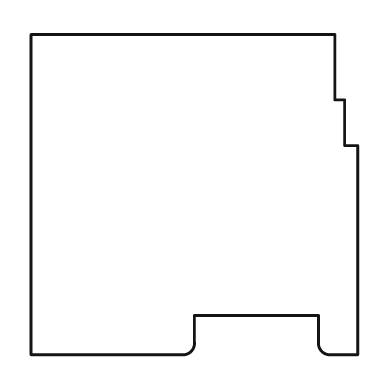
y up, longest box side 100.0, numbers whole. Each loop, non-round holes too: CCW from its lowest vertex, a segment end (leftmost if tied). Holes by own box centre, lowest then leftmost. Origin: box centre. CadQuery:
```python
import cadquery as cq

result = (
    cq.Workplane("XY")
    .moveTo(-50.0, -49.0)
    .lineTo(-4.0, -49.0)
    .threePointArc((-1.0, -48.0), (0.0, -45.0))
    .lineTo(0.0, -37.0)
    .lineTo(38.0, -37.0)
    .lineTo(38.0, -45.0)
    .threePointArc((39.0, -48.0), (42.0, -49.0))
    .lineTo(50.0, -49.0)
    .lineTo(50.0, 15.0)
    .lineTo(46.0, 15.0)
    .lineTo(46.0, 29.0)
    .lineTo(43.0, 29.0)
    .lineTo(43.0, 49.0)
    .lineTo(-50.0, 49.0)
    .close()
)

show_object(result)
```